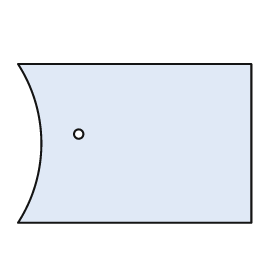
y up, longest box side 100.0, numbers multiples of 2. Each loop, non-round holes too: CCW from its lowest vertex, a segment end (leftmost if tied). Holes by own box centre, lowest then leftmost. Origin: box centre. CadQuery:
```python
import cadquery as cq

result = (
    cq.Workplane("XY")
    .moveTo(-50.0, -34.0)
    .lineTo(50.0, -34.0)
    .lineTo(50.0, 34.0)
    .lineTo(-50.0, 34.0)
    .threePointArc((-40.0, 0.0), (-50.0, -34.0))
    .close()
    .moveTo(-24.0, 4.0)
    .circle(2.0)
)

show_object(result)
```